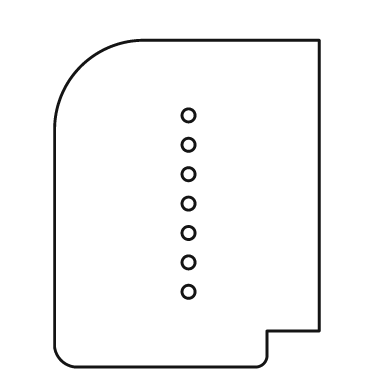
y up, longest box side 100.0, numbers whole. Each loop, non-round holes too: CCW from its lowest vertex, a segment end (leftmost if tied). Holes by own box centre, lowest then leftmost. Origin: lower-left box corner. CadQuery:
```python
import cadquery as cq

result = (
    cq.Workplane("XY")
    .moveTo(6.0, 0.0)
    .lineTo(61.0, 0.0)
    .threePointArc((64.0, 1.0), (65.0, 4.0))
    .lineTo(65.0, 11.0)
    .lineTo(81.0, 11.0)
    .lineTo(81.0, 100.0)
    .lineTo(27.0, 100.0)
    .threePointArc((8.0, 92.0), (0.0, 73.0))
    .lineTo(0.0, 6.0)
    .threePointArc((2.0, 2.0), (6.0, 0.0))
    .close()
    .moveTo(41.0, 23.0)
    .circle(2.0)
    .moveTo(41.0, 32.0)
    .circle(2.0)
    .moveTo(41.0, 41.0)
    .circle(2.0)
    .moveTo(41.0, 50.0)
    .circle(2.0)
    .moveTo(41.0, 59.0)
    .circle(2.0)
    .moveTo(41.0, 68.0)
    .circle(2.0)
    .moveTo(41.0, 77.0)
    .circle(2.0)
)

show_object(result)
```